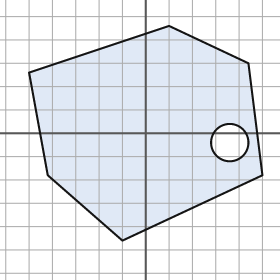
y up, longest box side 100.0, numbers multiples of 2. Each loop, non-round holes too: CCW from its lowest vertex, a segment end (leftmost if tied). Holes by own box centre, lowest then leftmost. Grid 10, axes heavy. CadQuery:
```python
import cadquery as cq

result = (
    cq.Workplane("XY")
    .moveTo(-10.0, -46.0)
    .lineTo(50.0, -18.0)
    .lineTo(44.0, 30.0)
    .lineTo(10.0, 46.0)
    .lineTo(-50.0, 26.0)
    .lineTo(-42.0, -18.0)
    .close()
    .moveTo(36.0, -4.0)
    .circle(8.0)
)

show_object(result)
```